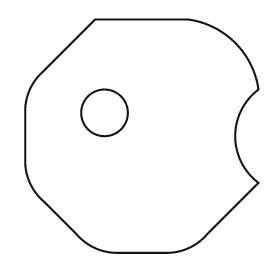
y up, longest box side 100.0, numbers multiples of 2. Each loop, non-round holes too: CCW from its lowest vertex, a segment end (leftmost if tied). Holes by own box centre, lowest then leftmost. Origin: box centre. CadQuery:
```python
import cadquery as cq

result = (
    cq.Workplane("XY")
    .moveTo(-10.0, -50.0)
    .lineTo(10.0, -50.0)
    .threePointArc((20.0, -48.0), (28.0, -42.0))
    .lineTo(50.0, -20.0)
    .threePointArc((40.0, 0.0), (50.0, 20.0))
    .threePointArc((40.0, 40.0), (20.0, 50.0))
    .lineTo(-20.0, 50.0)
    .lineTo(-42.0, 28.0)
    .threePointArc((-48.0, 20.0), (-50.0, 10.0))
    .lineTo(-50.0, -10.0)
    .threePointArc((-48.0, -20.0), (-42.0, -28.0))
    .lineTo(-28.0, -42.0)
    .threePointArc((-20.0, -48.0), (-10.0, -50.0))
    .close()
    .moveTo(-16.0, 10.0)
    .circle(10.0)
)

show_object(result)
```